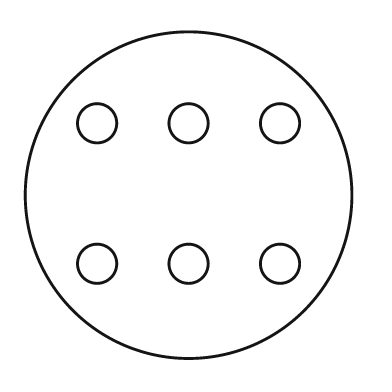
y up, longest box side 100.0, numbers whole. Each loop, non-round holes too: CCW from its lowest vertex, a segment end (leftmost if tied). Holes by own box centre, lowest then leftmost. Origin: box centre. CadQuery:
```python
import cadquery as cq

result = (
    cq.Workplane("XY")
    .moveTo(0.0, 0.0)
    .circle(50.0)
    .moveTo(-28.0, -21.0)
    .circle(6.0)
    .moveTo(0.0, -21.0)
    .circle(6.0)
    .moveTo(28.0, -21.0)
    .circle(6.0)
    .moveTo(-28.0, 22.0)
    .circle(6.0)
    .moveTo(0.0, 22.0)
    .circle(6.0)
    .moveTo(28.0, 22.0)
    .circle(6.0)
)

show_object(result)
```